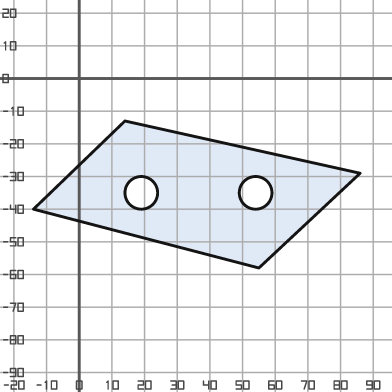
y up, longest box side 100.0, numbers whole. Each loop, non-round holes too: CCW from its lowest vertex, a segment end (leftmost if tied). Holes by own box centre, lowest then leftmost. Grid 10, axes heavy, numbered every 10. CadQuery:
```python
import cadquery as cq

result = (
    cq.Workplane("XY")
    .moveTo(55.0, -58.0)
    .lineTo(86.0, -29.0)
    .lineTo(14.0, -13.0)
    .lineTo(-14.0, -40.0)
    .close()
    .moveTo(19.0, -35.0)
    .circle(5.0)
    .moveTo(54.0, -35.0)
    .circle(5.0)
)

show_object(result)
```